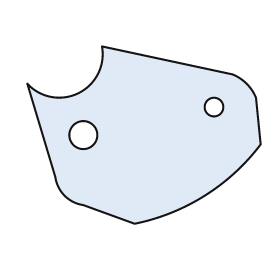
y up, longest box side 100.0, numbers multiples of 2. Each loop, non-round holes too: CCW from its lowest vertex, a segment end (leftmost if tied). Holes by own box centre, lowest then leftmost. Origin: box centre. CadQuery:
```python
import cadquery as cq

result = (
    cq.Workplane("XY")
    .moveTo(-4.0, -38.0)
    .threePointArc((26.0, -26.0), (50.0, -4.0))
    .lineTo(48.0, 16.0)
    .threePointArc((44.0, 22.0), (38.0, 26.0))
    .lineTo(-18.0, 38.0)
    .threePointArc((-28.0, 18.0), (-50.0, 22.0))
    .lineTo(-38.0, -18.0)
    .threePointArc((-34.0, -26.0), (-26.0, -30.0))
    .close()
    .moveTo(-26.0, 0.0)
    .circle(6.0)
    .moveTo(30.0, 12.0)
    .circle(4.0)
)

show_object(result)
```